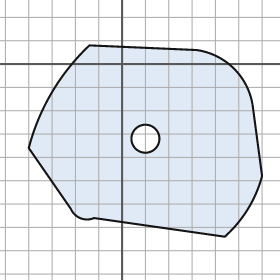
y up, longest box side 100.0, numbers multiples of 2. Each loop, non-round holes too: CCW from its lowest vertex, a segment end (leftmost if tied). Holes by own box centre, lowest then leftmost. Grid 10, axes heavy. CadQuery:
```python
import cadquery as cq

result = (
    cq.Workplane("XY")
    .moveTo(44.0, -74.0)
    .threePointArc((54.0, -62.0), (60.0, -48.0))
    .lineTo(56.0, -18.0)
    .threePointArc((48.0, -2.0), (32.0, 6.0))
    .lineTo(-14.0, 8.0)
    .threePointArc((-30.0, -12.0), (-40.0, -36.0))
    .lineTo(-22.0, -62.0)
    .threePointArc((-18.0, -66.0), (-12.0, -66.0))
    .close()
    .moveTo(10.0, -32.0)
    .circle(6.0)
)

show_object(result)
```